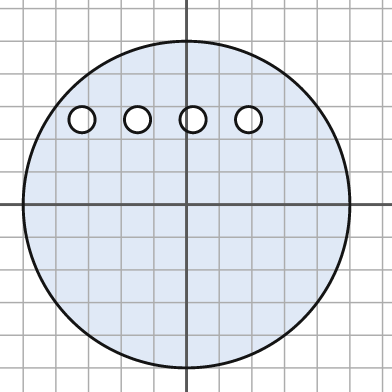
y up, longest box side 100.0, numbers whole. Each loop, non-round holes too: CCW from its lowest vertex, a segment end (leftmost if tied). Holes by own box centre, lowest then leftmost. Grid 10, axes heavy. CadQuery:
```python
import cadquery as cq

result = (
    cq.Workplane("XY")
    .moveTo(0.0, 0.0)
    .circle(50.0)
    .moveTo(-32.0, 26.0)
    .circle(4.0)
    .moveTo(-15.0, 26.0)
    .circle(4.0)
    .moveTo(2.0, 26.0)
    .circle(4.0)
    .moveTo(19.0, 26.0)
    .circle(4.0)
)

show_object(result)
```